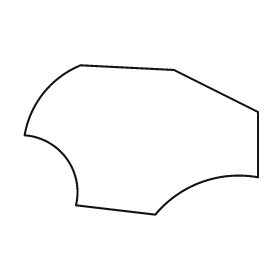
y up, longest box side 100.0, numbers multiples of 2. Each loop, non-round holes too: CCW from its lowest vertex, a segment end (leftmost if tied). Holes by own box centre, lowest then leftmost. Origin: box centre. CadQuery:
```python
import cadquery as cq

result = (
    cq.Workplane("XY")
    .moveTo(6.0, -32.0)
    .threePointArc((26.0, -18.0), (50.0, -16.0))
    .lineTo(50.0, 12.0)
    .lineTo(14.0, 30.0)
    .lineTo(-26.0, 32.0)
    .threePointArc((-42.0, 20.0), (-50.0, 2.0))
    .threePointArc((-32.0, -8.0), (-28.0, -28.0))
    .close()
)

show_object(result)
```